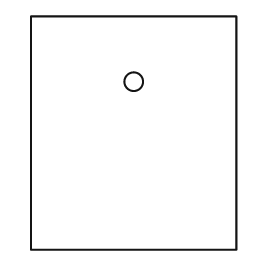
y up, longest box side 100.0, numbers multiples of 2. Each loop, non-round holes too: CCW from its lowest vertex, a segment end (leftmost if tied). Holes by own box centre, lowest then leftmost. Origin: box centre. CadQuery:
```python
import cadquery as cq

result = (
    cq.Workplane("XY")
    .moveTo(-44.0, -50.0)
    .lineTo(44.0, -50.0)
    .lineTo(44.0, 50.0)
    .lineTo(-44.0, 50.0)
    .close()
    .moveTo(0.0, 22.0)
    .circle(4.0)
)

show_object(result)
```